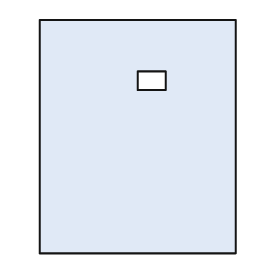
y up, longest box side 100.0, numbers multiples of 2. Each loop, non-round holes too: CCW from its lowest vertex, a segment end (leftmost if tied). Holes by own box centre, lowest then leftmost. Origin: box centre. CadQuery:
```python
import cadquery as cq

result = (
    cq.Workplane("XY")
    .moveTo(-42.0, -50.0)
    .lineTo(42.0, -50.0)
    .lineTo(42.0, 50.0)
    .lineTo(-42.0, 50.0)
    .close()
    .moveTo(0.0, 20.0)
    .lineTo(12.0, 20.0)
    .lineTo(12.0, 28.0)
    .lineTo(0.0, 28.0)
    .close()
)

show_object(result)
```